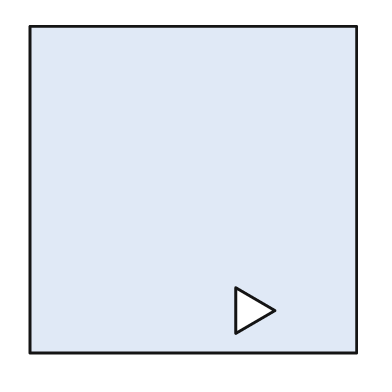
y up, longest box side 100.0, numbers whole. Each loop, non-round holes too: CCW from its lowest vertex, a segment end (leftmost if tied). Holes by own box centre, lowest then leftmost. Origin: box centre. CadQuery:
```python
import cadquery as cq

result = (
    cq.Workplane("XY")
    .moveTo(-50.0, -50.0)
    .lineTo(50.0, -50.0)
    .lineTo(50.0, 50.0)
    .lineTo(-50.0, 50.0)
    .close()
    .moveTo(13.0, -44.0)
    .lineTo(25.0, -37.0)
    .lineTo(13.0, -30.0)
    .close()
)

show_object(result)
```